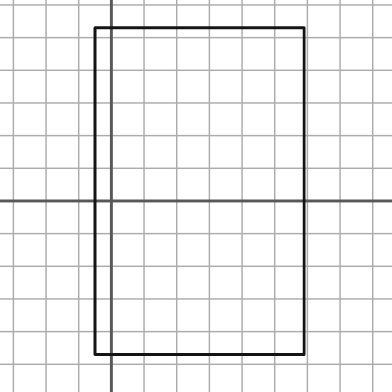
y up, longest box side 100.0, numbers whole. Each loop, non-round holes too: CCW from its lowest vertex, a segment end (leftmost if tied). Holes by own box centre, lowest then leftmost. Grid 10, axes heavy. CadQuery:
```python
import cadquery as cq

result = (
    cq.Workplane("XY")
    .moveTo(-5.0, -47.0)
    .lineTo(59.0, -47.0)
    .lineTo(59.0, 53.0)
    .lineTo(-5.0, 53.0)
    .close()
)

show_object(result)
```